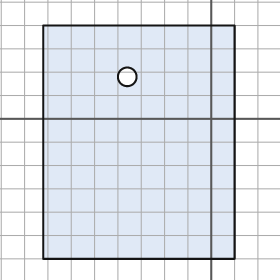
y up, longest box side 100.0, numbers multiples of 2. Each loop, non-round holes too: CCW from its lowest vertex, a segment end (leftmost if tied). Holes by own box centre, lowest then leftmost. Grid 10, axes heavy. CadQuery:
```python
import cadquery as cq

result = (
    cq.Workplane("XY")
    .moveTo(-72.0, -60.0)
    .lineTo(10.0, -60.0)
    .lineTo(10.0, 40.0)
    .lineTo(-72.0, 40.0)
    .close()
    .moveTo(-36.0, 18.0)
    .circle(4.0)
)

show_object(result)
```